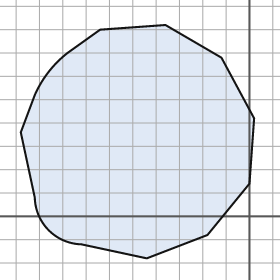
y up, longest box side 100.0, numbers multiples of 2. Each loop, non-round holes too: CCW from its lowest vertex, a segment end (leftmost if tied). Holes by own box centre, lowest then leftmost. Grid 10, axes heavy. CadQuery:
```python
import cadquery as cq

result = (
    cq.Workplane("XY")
    .moveTo(-44.0, -18.0)
    .lineTo(-18.0, -8.0)
    .lineTo(0.0, 14.0)
    .lineTo(2.0, 42.0)
    .lineTo(-12.0, 68.0)
    .lineTo(-36.0, 82.0)
    .lineTo(-64.0, 80.0)
    .lineTo(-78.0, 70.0)
    .threePointArc((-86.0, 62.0), (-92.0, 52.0))
    .lineTo(-98.0, 36.0)
    .lineTo(-92.0, 8.0)
    .threePointArc((-86.0, -6.0), (-72.0, -12.0))
    .close()
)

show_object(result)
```